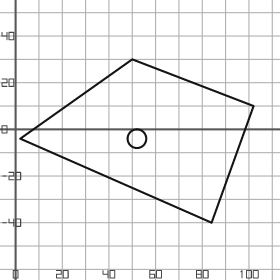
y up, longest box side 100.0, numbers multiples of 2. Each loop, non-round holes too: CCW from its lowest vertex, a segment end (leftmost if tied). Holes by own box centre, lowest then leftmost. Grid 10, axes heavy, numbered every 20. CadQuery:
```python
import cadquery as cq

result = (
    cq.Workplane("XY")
    .moveTo(84.0, -40.0)
    .lineTo(102.0, 10.0)
    .lineTo(50.0, 30.0)
    .lineTo(2.0, -4.0)
    .close()
    .moveTo(52.0, -4.0)
    .circle(4.0)
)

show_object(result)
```